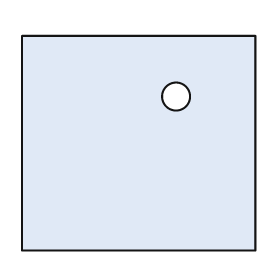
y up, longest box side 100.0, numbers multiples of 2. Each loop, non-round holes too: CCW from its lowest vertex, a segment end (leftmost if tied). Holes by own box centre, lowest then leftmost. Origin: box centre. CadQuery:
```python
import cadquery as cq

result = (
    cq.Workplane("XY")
    .moveTo(-50.0, -46.0)
    .lineTo(50.0, -46.0)
    .lineTo(50.0, 46.0)
    .lineTo(-50.0, 46.0)
    .close()
    .moveTo(16.0, 20.0)
    .circle(6.0)
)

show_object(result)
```